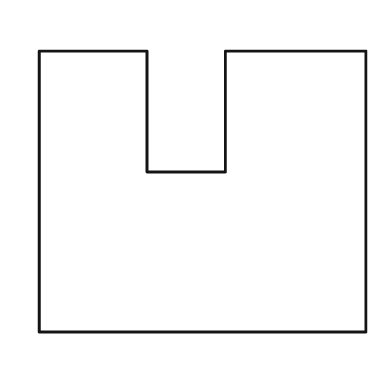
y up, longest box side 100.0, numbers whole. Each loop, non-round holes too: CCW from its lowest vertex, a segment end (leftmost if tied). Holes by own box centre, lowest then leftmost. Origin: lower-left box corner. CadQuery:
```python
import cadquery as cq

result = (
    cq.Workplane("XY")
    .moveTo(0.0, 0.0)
    .lineTo(100.0, 0.0)
    .lineTo(100.0, 86.0)
    .lineTo(57.0, 86.0)
    .lineTo(57.0, 49.0)
    .lineTo(33.0, 49.0)
    .lineTo(33.0, 86.0)
    .lineTo(0.0, 86.0)
    .close()
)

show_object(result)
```